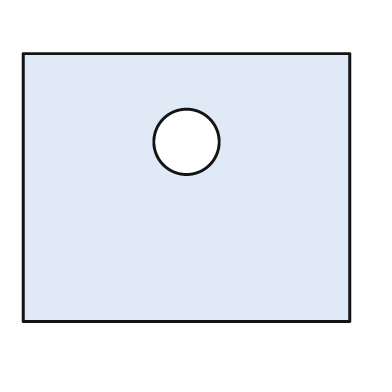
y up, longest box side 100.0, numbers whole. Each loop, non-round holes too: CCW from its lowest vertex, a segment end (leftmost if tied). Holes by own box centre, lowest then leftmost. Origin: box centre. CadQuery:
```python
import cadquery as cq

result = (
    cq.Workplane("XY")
    .moveTo(-50.0, -41.0)
    .lineTo(50.0, -41.0)
    .lineTo(50.0, 41.0)
    .lineTo(-50.0, 41.0)
    .close()
    .moveTo(0.0, 14.0)
    .circle(10.0)
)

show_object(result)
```